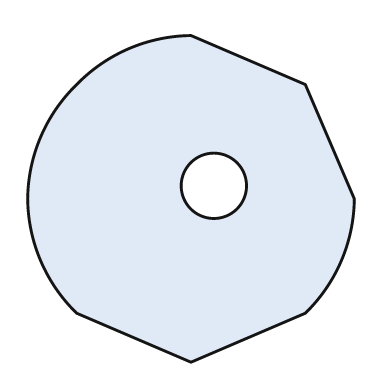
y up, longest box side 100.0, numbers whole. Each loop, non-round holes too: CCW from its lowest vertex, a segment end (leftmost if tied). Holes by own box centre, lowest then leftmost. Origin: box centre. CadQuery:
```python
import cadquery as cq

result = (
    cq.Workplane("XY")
    .moveTo(0.0, -50.0)
    .lineTo(35.0, -35.0)
    .threePointArc((46.0, -19.0), (50.0, 0.0))
    .lineTo(35.0, 35.0)
    .lineTo(0.0, 50.0)
    .threePointArc((-19.0, 46.0), (-35.0, 35.0))
    .threePointArc((-46.0, 19.0), (-50.0, 0.0))
    .threePointArc((-46.0, -19.0), (-35.0, -35.0))
    .close()
    .moveTo(7.0, 4.0)
    .circle(10.0)
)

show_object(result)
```